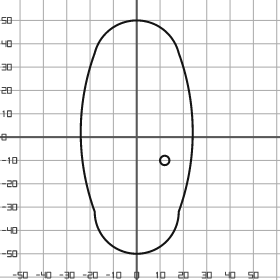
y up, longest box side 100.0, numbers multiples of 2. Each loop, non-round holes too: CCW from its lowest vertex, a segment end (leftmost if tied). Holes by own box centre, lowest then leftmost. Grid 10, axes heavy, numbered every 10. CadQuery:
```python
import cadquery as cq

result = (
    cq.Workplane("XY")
    .moveTo(-18.0, -32.0)
    .threePointArc((0.0, -50.0), (18.0, -32.0))
    .threePointArc((24.0, 2.0), (18.0, 36.0))
    .threePointArc((0.0, 50.0), (-18.0, 36.0))
    .threePointArc((-24.0, 2.0), (-18.0, -32.0))
    .close()
    .moveTo(12.0, -10.0)
    .circle(2.0)
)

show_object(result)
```